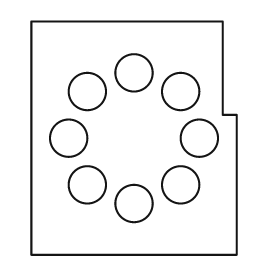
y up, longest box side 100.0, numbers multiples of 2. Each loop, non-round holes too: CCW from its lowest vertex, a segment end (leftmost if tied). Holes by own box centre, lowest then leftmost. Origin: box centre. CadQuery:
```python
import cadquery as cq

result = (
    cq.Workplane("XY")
    .moveTo(-44.0, -50.0)
    .lineTo(44.0, -50.0)
    .lineTo(44.0, 10.0)
    .lineTo(38.0, 10.0)
    .lineTo(38.0, 50.0)
    .lineTo(-44.0, 50.0)
    .close()
    .moveTo(0.0, -28.0)
    .circle(8.0)
    .moveTo(-20.0, -20.0)
    .circle(8.0)
    .moveTo(20.0, -20.0)
    .circle(8.0)
    .moveTo(-28.0, 0.0)
    .circle(8.0)
    .moveTo(28.0, 0.0)
    .circle(8.0)
    .moveTo(-20.0, 20.0)
    .circle(8.0)
    .moveTo(20.0, 20.0)
    .circle(8.0)
    .moveTo(0.0, 28.0)
    .circle(8.0)
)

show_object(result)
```